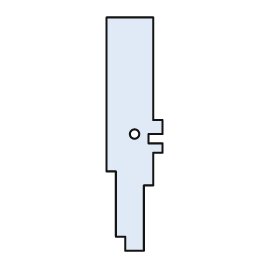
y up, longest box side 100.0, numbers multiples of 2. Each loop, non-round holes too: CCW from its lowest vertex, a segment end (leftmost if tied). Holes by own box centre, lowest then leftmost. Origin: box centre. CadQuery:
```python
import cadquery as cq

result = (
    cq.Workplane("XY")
    .moveTo(-4.0, -50.0)
    .lineTo(4.0, -50.0)
    .lineTo(4.0, -22.0)
    .lineTo(8.0, -22.0)
    .lineTo(8.0, -8.0)
    .lineTo(12.0, -8.0)
    .lineTo(12.0, -4.0)
    .lineTo(6.0, -4.0)
    .lineTo(6.0, 0.0)
    .lineTo(12.0, 0.0)
    .lineTo(12.0, 6.0)
    .lineTo(8.0, 6.0)
    .lineTo(8.0, 50.0)
    .lineTo(-12.0, 50.0)
    .lineTo(-12.0, -16.0)
    .lineTo(-8.0, -16.0)
    .lineTo(-8.0, -44.0)
    .lineTo(-4.0, -44.0)
    .close()
    .moveTo(0.0, 0.0)
    .circle(2.0)
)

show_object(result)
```